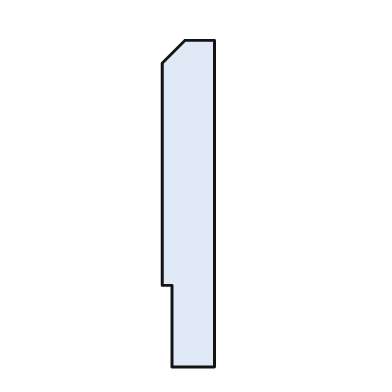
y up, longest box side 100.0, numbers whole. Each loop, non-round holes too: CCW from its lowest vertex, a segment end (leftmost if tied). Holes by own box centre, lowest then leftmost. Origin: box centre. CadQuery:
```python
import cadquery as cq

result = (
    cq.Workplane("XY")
    .moveTo(-5.0, -50.0)
    .lineTo(8.0, -50.0)
    .lineTo(8.0, 50.0)
    .lineTo(-1.0, 50.0)
    .lineTo(-8.0, 43.0)
    .lineTo(-8.0, -25.0)
    .lineTo(-5.0, -25.0)
    .close()
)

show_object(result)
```